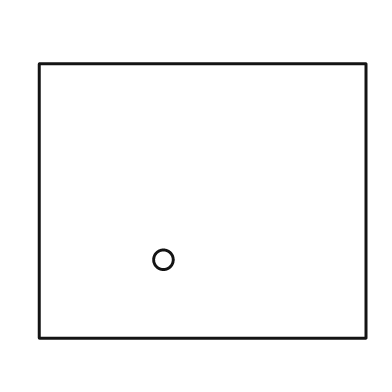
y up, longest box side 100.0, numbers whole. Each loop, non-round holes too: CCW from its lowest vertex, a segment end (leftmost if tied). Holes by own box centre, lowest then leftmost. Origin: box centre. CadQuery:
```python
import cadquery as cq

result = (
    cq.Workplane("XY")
    .moveTo(-50.0, -42.0)
    .lineTo(50.0, -42.0)
    .lineTo(50.0, 42.0)
    .lineTo(-50.0, 42.0)
    .close()
    .moveTo(-12.0, -18.0)
    .circle(3.0)
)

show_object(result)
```